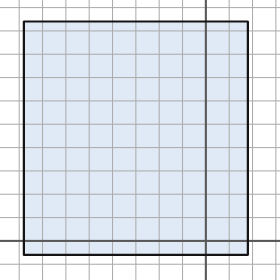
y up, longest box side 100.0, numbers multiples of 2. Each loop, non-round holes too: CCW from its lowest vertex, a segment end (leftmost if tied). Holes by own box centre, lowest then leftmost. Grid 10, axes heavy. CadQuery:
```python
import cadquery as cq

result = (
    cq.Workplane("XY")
    .moveTo(-78.0, -6.0)
    .lineTo(18.0, -6.0)
    .lineTo(18.0, 94.0)
    .lineTo(-78.0, 94.0)
    .close()
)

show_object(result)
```